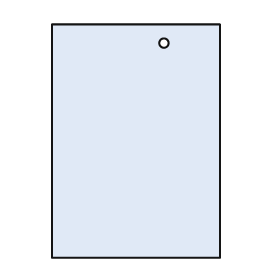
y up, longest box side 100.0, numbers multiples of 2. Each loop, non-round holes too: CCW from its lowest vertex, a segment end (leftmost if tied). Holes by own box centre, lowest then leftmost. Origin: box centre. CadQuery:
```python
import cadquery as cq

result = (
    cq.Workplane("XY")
    .moveTo(-36.0, -50.0)
    .lineTo(36.0, -50.0)
    .lineTo(36.0, 50.0)
    .lineTo(-36.0, 50.0)
    .close()
    .moveTo(12.0, 42.0)
    .circle(2.0)
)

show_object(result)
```